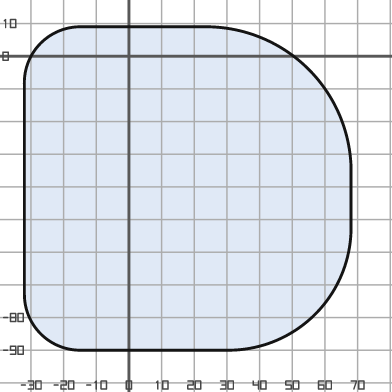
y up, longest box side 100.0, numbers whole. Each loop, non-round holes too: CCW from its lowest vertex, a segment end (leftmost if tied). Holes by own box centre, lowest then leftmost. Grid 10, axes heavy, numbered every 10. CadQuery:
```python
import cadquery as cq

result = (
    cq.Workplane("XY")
    .moveTo(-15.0, -90.0)
    .lineTo(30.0, -90.0)
    .threePointArc((57.0, -79.0), (68.0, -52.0))
    .lineTo(68.0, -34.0)
    .threePointArc((55.0, -4.0), (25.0, 9.0))
    .lineTo(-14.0, 9.0)
    .threePointArc((-27.0, 4.0), (-32.0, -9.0))
    .lineTo(-32.0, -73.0)
    .threePointArc((-27.0, -85.0), (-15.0, -90.0))
    .close()
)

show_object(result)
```